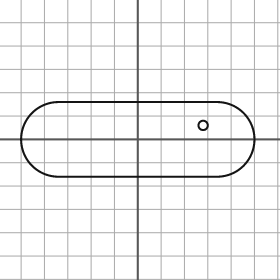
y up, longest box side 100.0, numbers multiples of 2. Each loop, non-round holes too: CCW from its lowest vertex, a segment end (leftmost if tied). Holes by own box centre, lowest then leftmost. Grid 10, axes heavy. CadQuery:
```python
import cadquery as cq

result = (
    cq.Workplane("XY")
    .moveTo(-34.0, -16.0)
    .lineTo(34.0, -16.0)
    .threePointArc((50.0, 0.0), (34.0, 16.0))
    .lineTo(-34.0, 16.0)
    .threePointArc((-50.0, 0.0), (-34.0, -16.0))
    .close()
    .moveTo(28.0, 6.0)
    .circle(2.0)
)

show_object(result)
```